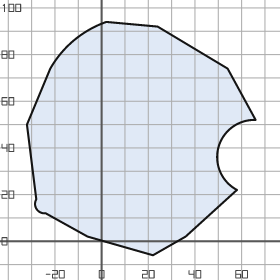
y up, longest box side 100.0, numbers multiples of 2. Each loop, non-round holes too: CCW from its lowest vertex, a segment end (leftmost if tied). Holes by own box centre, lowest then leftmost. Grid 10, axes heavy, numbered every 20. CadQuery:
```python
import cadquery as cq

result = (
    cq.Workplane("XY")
    .moveTo(22.0, -6.0)
    .lineTo(36.0, 2.0)
    .lineTo(58.0, 22.0)
    .threePointArc((50.0, 40.0), (66.0, 52.0))
    .lineTo(54.0, 74.0)
    .lineTo(24.0, 92.0)
    .lineTo(2.0, 94.0)
    .threePointArc((-12.0, 86.0), (-22.0, 74.0))
    .lineTo(-32.0, 50.0)
    .lineTo(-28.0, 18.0)
    .threePointArc((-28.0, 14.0), (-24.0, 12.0))
    .lineTo(-6.0, 2.0)
    .close()
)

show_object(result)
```